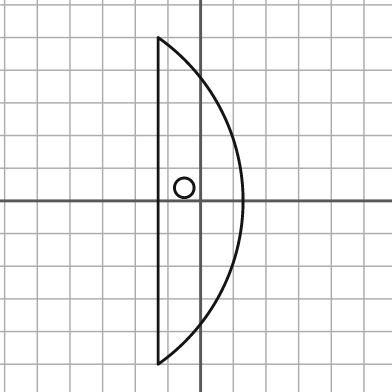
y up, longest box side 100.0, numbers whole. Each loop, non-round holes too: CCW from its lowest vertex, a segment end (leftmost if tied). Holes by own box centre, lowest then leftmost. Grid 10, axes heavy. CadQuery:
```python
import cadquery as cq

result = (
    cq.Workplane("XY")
    .moveTo(-13.0, -50.0)
    .threePointArc((13.0, 0.0), (-13.0, 50.0))
    .close()
    .moveTo(-5.0, 4.0)
    .circle(3.0)
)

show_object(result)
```